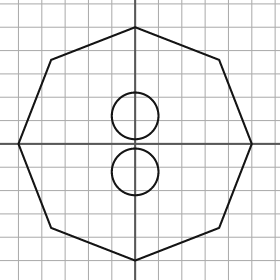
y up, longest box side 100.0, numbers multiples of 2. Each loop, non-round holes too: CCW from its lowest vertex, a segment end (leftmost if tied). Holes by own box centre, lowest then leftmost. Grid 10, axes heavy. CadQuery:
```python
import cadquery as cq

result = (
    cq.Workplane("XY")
    .moveTo(0.0, -50.0)
    .lineTo(36.0, -36.0)
    .lineTo(50.0, 0.0)
    .lineTo(36.0, 36.0)
    .lineTo(0.0, 50.0)
    .lineTo(-36.0, 36.0)
    .lineTo(-50.0, 0.0)
    .lineTo(-36.0, -36.0)
    .close()
    .moveTo(0.0, -12.0)
    .circle(10.0)
    .moveTo(0.0, 12.0)
    .circle(10.0)
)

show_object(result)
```